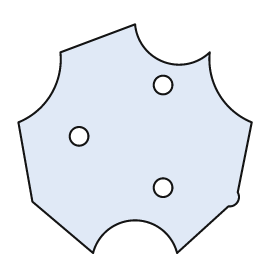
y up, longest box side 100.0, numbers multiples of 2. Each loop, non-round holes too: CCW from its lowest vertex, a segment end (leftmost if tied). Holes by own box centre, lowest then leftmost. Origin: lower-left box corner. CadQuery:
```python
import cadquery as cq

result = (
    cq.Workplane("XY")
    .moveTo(32.0, 0.0)
    .threePointArc((50.0, 14.0), (68.0, 0.0))
    .lineTo(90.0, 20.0)
    .threePointArc((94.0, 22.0), (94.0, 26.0))
    .lineTo(100.0, 56.0)
    .threePointArc((86.0, 68.0), (82.0, 86.0))
    .threePointArc((62.0, 82.0), (50.0, 98.0))
    .lineTo(18.0, 86.0)
    .threePointArc((14.0, 68.0), (0.0, 56.0))
    .lineTo(6.0, 22.0)
    .close()
    .moveTo(62.0, 28.0)
    .circle(4.0)
    .moveTo(26.0, 50.0)
    .circle(4.0)
    .moveTo(62.0, 72.0)
    .circle(4.0)
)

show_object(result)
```